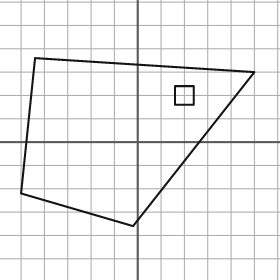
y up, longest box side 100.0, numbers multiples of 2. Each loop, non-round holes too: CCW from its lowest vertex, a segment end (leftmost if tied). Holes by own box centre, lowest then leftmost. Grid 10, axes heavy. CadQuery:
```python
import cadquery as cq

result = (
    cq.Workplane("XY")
    .moveTo(-2.0, -36.0)
    .lineTo(50.0, 30.0)
    .lineTo(-44.0, 36.0)
    .lineTo(-50.0, -22.0)
    .close()
    .moveTo(16.0, 16.0)
    .lineTo(24.0, 16.0)
    .lineTo(24.0, 24.0)
    .lineTo(16.0, 24.0)
    .close()
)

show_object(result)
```